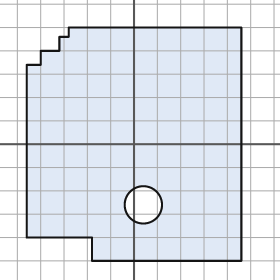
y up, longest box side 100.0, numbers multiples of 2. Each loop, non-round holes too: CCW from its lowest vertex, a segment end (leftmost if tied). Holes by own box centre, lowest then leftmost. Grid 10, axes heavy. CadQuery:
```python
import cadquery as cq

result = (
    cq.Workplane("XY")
    .moveTo(-18.0, -50.0)
    .lineTo(46.0, -50.0)
    .lineTo(46.0, 50.0)
    .lineTo(-28.0, 50.0)
    .lineTo(-28.0, 46.0)
    .lineTo(-32.0, 46.0)
    .lineTo(-32.0, 40.0)
    .lineTo(-40.0, 40.0)
    .lineTo(-40.0, 34.0)
    .lineTo(-46.0, 34.0)
    .lineTo(-46.0, -40.0)
    .lineTo(-18.0, -40.0)
    .close()
    .moveTo(4.0, -26.0)
    .circle(8.0)
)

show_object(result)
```